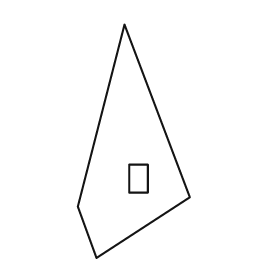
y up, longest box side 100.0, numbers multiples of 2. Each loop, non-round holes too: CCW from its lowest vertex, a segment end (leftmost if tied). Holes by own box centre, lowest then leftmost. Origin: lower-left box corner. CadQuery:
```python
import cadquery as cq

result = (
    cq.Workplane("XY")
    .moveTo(8.0, 0.0)
    .lineTo(48.0, 26.0)
    .lineTo(20.0, 100.0)
    .lineTo(0.0, 22.0)
    .close()
    .moveTo(22.0, 28.0)
    .lineTo(30.0, 28.0)
    .lineTo(30.0, 40.0)
    .lineTo(22.0, 40.0)
    .close()
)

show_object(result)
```